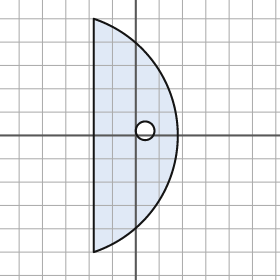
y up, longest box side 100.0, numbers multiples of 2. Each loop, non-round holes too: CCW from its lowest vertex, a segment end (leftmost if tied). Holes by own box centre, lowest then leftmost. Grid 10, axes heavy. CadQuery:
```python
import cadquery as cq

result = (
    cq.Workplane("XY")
    .moveTo(-18.0, -50.0)
    .threePointArc((18.0, 0.0), (-18.0, 50.0))
    .close()
    .moveTo(4.0, 2.0)
    .circle(4.0)
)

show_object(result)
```